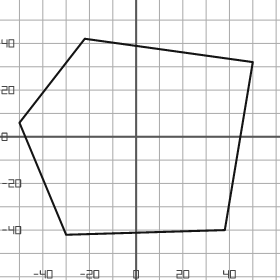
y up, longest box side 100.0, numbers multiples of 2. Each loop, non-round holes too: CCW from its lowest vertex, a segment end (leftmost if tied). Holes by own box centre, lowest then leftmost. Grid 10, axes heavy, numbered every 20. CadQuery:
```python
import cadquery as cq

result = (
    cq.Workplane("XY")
    .moveTo(-30.0, -42.0)
    .lineTo(38.0, -40.0)
    .lineTo(50.0, 32.0)
    .lineTo(-22.0, 42.0)
    .lineTo(-50.0, 6.0)
    .close()
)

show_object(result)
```